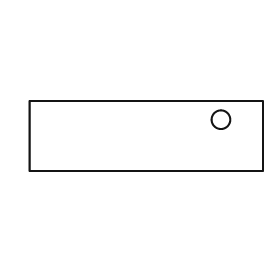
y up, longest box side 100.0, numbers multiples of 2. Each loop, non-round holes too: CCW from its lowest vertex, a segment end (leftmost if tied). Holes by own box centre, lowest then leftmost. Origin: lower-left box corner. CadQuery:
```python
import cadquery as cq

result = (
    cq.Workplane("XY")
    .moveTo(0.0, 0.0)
    .lineTo(100.0, 0.0)
    .lineTo(100.0, 30.0)
    .lineTo(0.0, 30.0)
    .close()
    .moveTo(82.0, 22.0)
    .circle(4.0)
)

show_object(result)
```